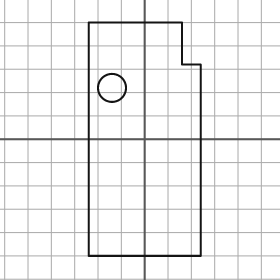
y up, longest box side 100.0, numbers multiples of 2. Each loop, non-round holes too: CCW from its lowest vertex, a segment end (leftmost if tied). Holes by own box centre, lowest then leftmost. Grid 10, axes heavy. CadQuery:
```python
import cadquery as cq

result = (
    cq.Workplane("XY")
    .moveTo(-24.0, -50.0)
    .lineTo(24.0, -50.0)
    .lineTo(24.0, 32.0)
    .lineTo(16.0, 32.0)
    .lineTo(16.0, 50.0)
    .lineTo(-24.0, 50.0)
    .close()
    .moveTo(-14.0, 22.0)
    .circle(6.0)
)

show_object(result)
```